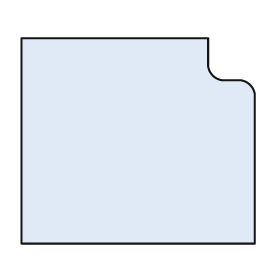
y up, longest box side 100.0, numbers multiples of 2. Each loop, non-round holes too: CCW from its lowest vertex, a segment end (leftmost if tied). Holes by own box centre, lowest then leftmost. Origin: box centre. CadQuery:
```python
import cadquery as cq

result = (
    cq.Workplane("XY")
    .moveTo(-50.0, -44.0)
    .lineTo(50.0, -44.0)
    .lineTo(50.0, 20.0)
    .threePointArc((48.0, 24.0), (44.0, 26.0))
    .lineTo(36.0, 26.0)
    .threePointArc((32.0, 28.0), (30.0, 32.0))
    .lineTo(30.0, 44.0)
    .lineTo(-50.0, 44.0)
    .close()
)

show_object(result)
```